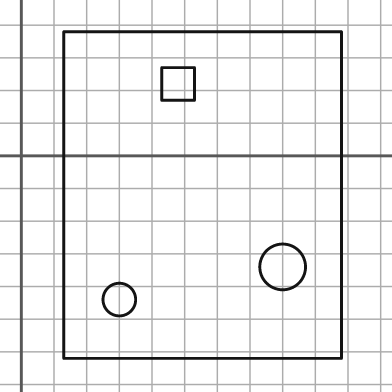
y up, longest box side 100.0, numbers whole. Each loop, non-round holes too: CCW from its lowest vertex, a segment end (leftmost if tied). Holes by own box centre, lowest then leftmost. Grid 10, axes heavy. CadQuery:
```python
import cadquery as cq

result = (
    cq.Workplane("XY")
    .moveTo(13.0, -62.0)
    .lineTo(98.0, -62.0)
    .lineTo(98.0, 38.0)
    .lineTo(13.0, 38.0)
    .close()
    .moveTo(30.0, -44.0)
    .circle(5.0)
    .moveTo(80.0, -34.0)
    .circle(7.0)
    .moveTo(43.0, 17.0)
    .lineTo(53.0, 17.0)
    .lineTo(53.0, 27.0)
    .lineTo(43.0, 27.0)
    .close()
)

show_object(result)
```